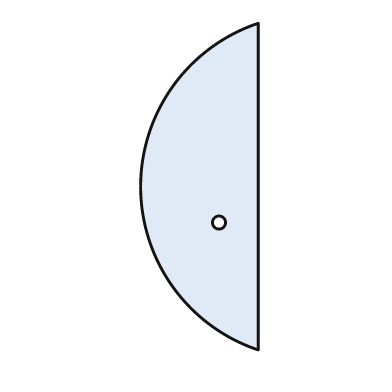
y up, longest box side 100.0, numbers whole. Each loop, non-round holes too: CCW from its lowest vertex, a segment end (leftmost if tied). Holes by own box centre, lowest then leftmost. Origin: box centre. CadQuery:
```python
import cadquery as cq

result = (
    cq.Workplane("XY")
    .moveTo(18.0, -50.0)
    .lineTo(18.0, 50.0)
    .threePointArc((-18.0, 0.0), (18.0, -50.0))
    .close()
    .moveTo(6.0, -11.0)
    .circle(2.0)
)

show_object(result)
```